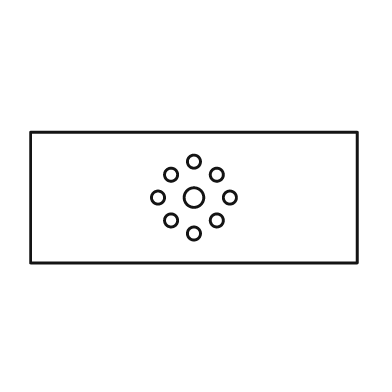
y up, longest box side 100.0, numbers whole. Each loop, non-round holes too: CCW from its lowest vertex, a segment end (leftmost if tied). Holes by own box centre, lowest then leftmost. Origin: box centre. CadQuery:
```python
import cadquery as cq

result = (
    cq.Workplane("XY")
    .moveTo(-50.0, -20.0)
    .lineTo(50.0, -20.0)
    .lineTo(50.0, 20.0)
    .lineTo(-50.0, 20.0)
    .close()
    .moveTo(0.0, -11.0)
    .circle(2.0)
    .moveTo(-7.0, -7.0)
    .circle(2.0)
    .moveTo(7.0, -7.0)
    .circle(2.0)
    .moveTo(-11.0, 0.0)
    .circle(2.0)
    .moveTo(0.0, 0.0)
    .circle(3.0)
    .moveTo(11.0, 0.0)
    .circle(2.0)
    .moveTo(-7.0, 7.0)
    .circle(2.0)
    .moveTo(7.0, 7.0)
    .circle(2.0)
    .moveTo(0.0, 11.0)
    .circle(2.0)
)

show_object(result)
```